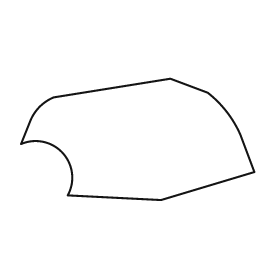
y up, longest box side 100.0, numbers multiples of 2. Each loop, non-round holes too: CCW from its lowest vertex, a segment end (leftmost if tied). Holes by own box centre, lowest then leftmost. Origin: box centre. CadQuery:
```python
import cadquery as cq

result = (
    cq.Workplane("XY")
    .moveTo(10.0, -26.0)
    .lineTo(50.0, -14.0)
    .lineTo(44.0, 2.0)
    .threePointArc((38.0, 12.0), (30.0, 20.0))
    .lineTo(14.0, 26.0)
    .lineTo(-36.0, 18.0)
    .threePointArc((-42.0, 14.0), (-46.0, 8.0))
    .lineTo(-50.0, -2.0)
    .threePointArc((-32.0, -6.0), (-30.0, -24.0))
    .close()
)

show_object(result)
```